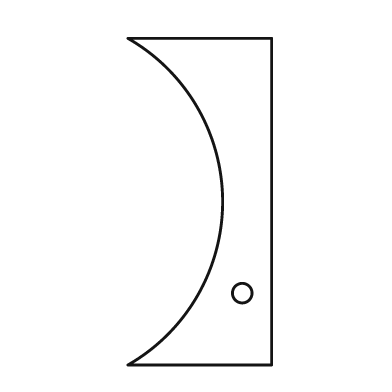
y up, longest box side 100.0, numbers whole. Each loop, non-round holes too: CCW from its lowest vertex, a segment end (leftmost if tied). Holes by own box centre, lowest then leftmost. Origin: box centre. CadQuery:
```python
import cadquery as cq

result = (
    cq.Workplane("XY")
    .moveTo(-22.0, -50.0)
    .lineTo(22.0, -50.0)
    .lineTo(22.0, 50.0)
    .lineTo(-22.0, 50.0)
    .threePointArc((7.0, 0.0), (-22.0, -50.0))
    .close()
    .moveTo(13.0, -28.0)
    .circle(3.0)
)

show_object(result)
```